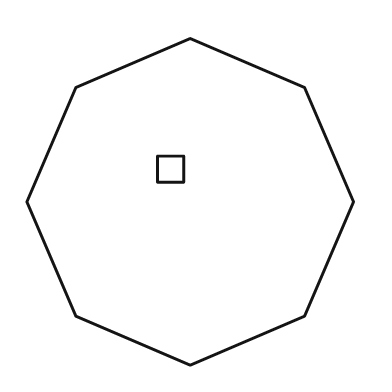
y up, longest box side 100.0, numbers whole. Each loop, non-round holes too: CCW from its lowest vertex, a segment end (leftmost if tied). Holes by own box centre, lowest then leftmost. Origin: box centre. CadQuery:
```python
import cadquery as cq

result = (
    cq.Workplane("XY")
    .moveTo(0.0, -50.0)
    .lineTo(35.0, -35.0)
    .lineTo(50.0, 0.0)
    .lineTo(35.0, 35.0)
    .lineTo(0.0, 50.0)
    .lineTo(-35.0, 35.0)
    .lineTo(-50.0, 0.0)
    .lineTo(-35.0, -35.0)
    .close()
    .moveTo(-10.0, 6.0)
    .lineTo(-2.0, 6.0)
    .lineTo(-2.0, 14.0)
    .lineTo(-10.0, 14.0)
    .close()
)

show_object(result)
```